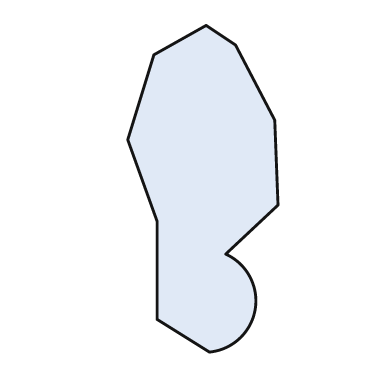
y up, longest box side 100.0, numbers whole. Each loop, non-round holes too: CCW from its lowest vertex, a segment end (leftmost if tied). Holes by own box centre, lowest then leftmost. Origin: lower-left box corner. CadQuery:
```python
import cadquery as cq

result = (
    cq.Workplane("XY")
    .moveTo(25.0, 0.0)
    .threePointArc((39.0, 13.0), (30.0, 30.0))
    .lineTo(46.0, 45.0)
    .lineTo(45.0, 71.0)
    .lineTo(33.0, 94.0)
    .lineTo(24.0, 100.0)
    .lineTo(8.0, 91.0)
    .lineTo(0.0, 65.0)
    .lineTo(9.0, 40.0)
    .lineTo(9.0, 10.0)
    .close()
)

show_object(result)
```